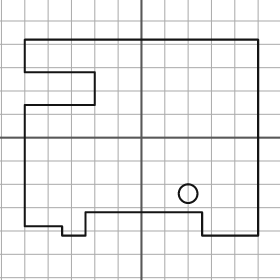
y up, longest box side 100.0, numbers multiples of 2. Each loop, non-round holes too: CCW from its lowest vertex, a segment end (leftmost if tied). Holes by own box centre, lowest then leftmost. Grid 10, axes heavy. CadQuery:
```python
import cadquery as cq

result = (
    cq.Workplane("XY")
    .moveTo(-34.0, -42.0)
    .lineTo(-24.0, -42.0)
    .lineTo(-24.0, -32.0)
    .lineTo(26.0, -32.0)
    .lineTo(26.0, -42.0)
    .lineTo(50.0, -42.0)
    .lineTo(50.0, 42.0)
    .lineTo(-50.0, 42.0)
    .lineTo(-50.0, 28.0)
    .lineTo(-20.0, 28.0)
    .lineTo(-20.0, 14.0)
    .lineTo(-50.0, 14.0)
    .lineTo(-50.0, -38.0)
    .lineTo(-34.0, -38.0)
    .close()
    .moveTo(20.0, -24.0)
    .circle(4.0)
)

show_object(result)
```